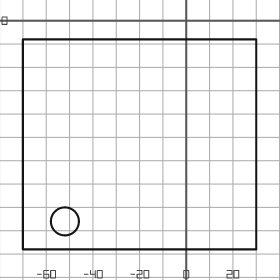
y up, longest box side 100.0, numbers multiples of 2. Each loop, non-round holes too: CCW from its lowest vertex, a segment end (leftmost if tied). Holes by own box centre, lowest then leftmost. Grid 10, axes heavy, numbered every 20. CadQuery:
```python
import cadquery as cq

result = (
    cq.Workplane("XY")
    .moveTo(-70.0, -98.0)
    .lineTo(30.0, -98.0)
    .lineTo(30.0, -8.0)
    .lineTo(-70.0, -8.0)
    .close()
    .moveTo(-52.0, -86.0)
    .circle(6.0)
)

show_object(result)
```